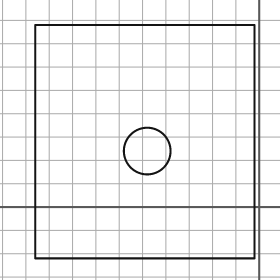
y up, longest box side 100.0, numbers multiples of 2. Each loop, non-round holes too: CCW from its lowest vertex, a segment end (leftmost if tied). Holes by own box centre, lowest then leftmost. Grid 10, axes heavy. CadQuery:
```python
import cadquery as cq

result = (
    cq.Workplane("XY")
    .moveTo(-96.0, -22.0)
    .lineTo(-2.0, -22.0)
    .lineTo(-2.0, 78.0)
    .lineTo(-96.0, 78.0)
    .close()
    .moveTo(-48.0, 24.0)
    .circle(10.0)
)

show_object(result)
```